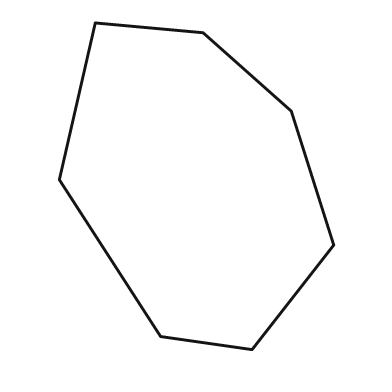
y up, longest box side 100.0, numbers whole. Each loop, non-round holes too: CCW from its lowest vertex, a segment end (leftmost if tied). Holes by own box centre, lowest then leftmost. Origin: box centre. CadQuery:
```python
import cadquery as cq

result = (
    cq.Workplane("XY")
    .moveTo(17.0, -50.0)
    .lineTo(42.0, -18.0)
    .lineTo(29.0, 23.0)
    .lineTo(2.0, 47.0)
    .lineTo(-31.0, 50.0)
    .lineTo(-42.0, 2.0)
    .lineTo(-11.0, -46.0)
    .close()
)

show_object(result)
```